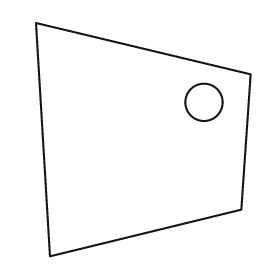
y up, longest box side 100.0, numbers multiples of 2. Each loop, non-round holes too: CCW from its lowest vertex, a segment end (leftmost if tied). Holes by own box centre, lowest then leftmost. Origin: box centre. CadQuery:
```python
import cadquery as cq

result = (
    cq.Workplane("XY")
    .moveTo(-40.0, -50.0)
    .lineTo(42.0, -30.0)
    .lineTo(46.0, 28.0)
    .lineTo(-46.0, 50.0)
    .close()
    .moveTo(26.0, 16.0)
    .circle(8.0)
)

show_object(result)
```